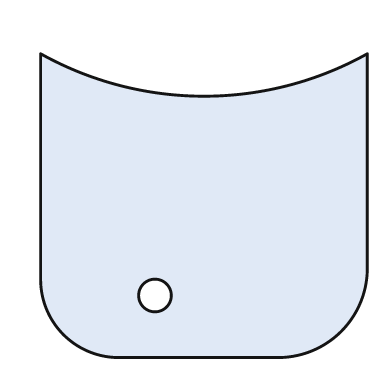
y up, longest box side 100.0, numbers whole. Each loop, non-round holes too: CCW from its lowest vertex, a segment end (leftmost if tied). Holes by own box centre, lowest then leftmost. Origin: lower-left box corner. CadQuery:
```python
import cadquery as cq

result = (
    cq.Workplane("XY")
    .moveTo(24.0, 0.0)
    .lineTo(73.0, 0.0)
    .threePointArc((92.0, 8.0), (100.0, 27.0))
    .lineTo(100.0, 93.0)
    .threePointArc((50.0, 80.0), (0.0, 93.0))
    .lineTo(0.0, 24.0)
    .threePointArc((7.0, 7.0), (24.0, 0.0))
    .close()
    .moveTo(35.0, 19.0)
    .circle(5.0)
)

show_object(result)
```